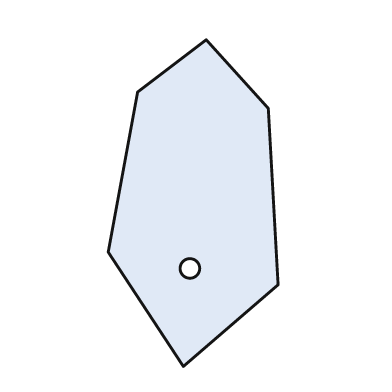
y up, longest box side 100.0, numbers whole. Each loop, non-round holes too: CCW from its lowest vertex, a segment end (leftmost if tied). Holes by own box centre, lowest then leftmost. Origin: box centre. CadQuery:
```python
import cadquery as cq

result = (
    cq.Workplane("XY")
    .moveTo(-3.0, -50.0)
    .lineTo(26.0, -25.0)
    .lineTo(23.0, 29.0)
    .lineTo(4.0, 50.0)
    .lineTo(-17.0, 34.0)
    .lineTo(-26.0, -15.0)
    .close()
    .moveTo(-1.0, -20.0)
    .circle(3.0)
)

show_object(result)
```